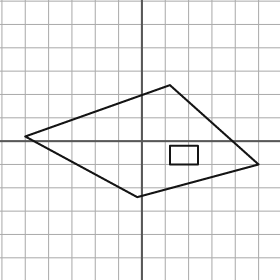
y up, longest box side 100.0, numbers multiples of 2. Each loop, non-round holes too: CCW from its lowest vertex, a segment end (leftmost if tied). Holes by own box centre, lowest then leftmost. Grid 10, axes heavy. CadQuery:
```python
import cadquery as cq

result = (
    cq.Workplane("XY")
    .moveTo(-2.0, -24.0)
    .lineTo(50.0, -10.0)
    .lineTo(12.0, 24.0)
    .lineTo(-50.0, 2.0)
    .close()
    .moveTo(12.0, -10.0)
    .lineTo(24.0, -10.0)
    .lineTo(24.0, -2.0)
    .lineTo(12.0, -2.0)
    .close()
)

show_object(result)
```